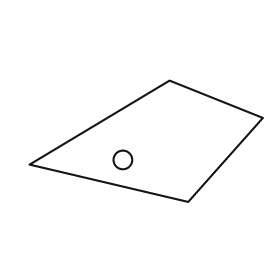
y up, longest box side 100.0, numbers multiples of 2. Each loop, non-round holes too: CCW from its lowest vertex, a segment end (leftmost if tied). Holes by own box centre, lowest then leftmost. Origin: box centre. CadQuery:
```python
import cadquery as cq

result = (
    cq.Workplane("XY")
    .moveTo(18.0, -26.0)
    .lineTo(50.0, 10.0)
    .lineTo(10.0, 26.0)
    .lineTo(-50.0, -10.0)
    .close()
    .moveTo(-10.0, -8.0)
    .circle(4.0)
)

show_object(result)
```